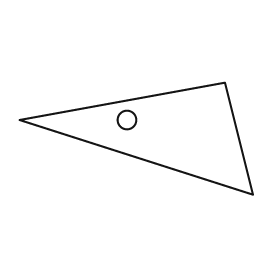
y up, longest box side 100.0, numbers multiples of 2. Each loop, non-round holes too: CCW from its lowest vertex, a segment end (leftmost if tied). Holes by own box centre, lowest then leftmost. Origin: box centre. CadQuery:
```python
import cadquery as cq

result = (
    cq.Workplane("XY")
    .moveTo(50.0, -24.0)
    .lineTo(38.0, 24.0)
    .lineTo(-50.0, 8.0)
    .close()
    .moveTo(-4.0, 8.0)
    .circle(4.0)
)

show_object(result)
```